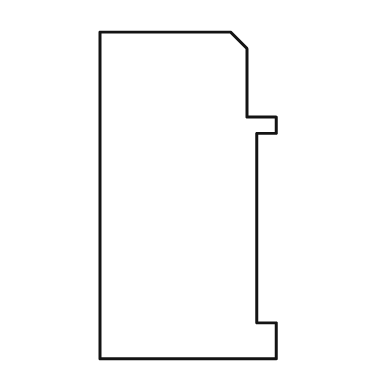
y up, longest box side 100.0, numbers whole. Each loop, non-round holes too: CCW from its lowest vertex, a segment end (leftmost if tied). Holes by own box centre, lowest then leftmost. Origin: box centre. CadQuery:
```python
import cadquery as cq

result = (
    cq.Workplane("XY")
    .moveTo(-27.0, -50.0)
    .lineTo(27.0, -50.0)
    .lineTo(27.0, -39.0)
    .lineTo(21.0, -39.0)
    .lineTo(21.0, 19.0)
    .lineTo(27.0, 19.0)
    .lineTo(27.0, 24.0)
    .lineTo(18.0, 24.0)
    .lineTo(18.0, 45.0)
    .lineTo(13.0, 50.0)
    .lineTo(-27.0, 50.0)
    .close()
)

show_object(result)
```